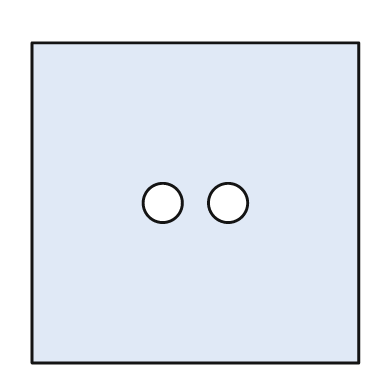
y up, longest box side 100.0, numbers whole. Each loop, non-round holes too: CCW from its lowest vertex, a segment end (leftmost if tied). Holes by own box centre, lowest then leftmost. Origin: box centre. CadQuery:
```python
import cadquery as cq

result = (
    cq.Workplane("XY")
    .moveTo(-50.0, -49.0)
    .lineTo(50.0, -49.0)
    .lineTo(50.0, 49.0)
    .lineTo(-50.0, 49.0)
    .close()
    .moveTo(-10.0, 0.0)
    .circle(6.0)
    .moveTo(10.0, 0.0)
    .circle(6.0)
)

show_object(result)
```